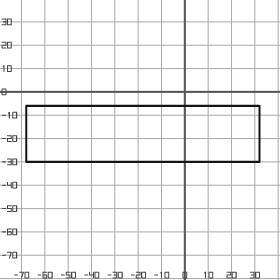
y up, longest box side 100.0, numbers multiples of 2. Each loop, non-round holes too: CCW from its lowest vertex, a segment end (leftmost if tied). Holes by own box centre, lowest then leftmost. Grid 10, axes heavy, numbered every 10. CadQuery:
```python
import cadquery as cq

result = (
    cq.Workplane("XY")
    .moveTo(-68.0, -30.0)
    .lineTo(32.0, -30.0)
    .lineTo(32.0, -6.0)
    .lineTo(-68.0, -6.0)
    .close()
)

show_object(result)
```